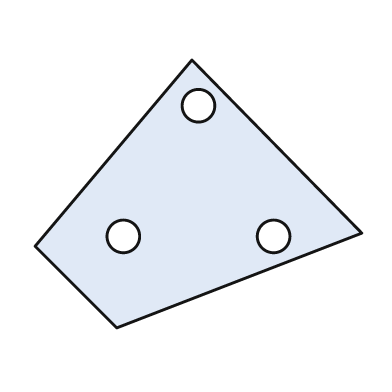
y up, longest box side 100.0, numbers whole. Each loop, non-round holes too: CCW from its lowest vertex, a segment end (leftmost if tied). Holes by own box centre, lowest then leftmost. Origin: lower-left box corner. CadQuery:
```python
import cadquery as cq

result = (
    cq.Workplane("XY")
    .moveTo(25.0, 0.0)
    .lineTo(100.0, 29.0)
    .lineTo(48.0, 82.0)
    .lineTo(0.0, 25.0)
    .close()
    .moveTo(27.0, 28.0)
    .circle(5.0)
    .moveTo(73.0, 28.0)
    .circle(5.0)
    .moveTo(50.0, 68.0)
    .circle(5.0)
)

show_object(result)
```